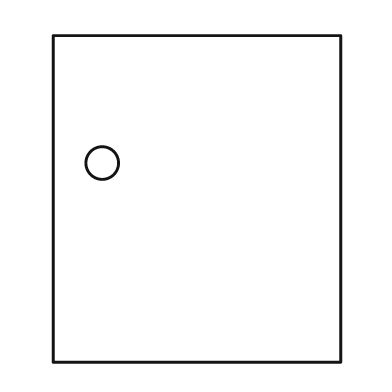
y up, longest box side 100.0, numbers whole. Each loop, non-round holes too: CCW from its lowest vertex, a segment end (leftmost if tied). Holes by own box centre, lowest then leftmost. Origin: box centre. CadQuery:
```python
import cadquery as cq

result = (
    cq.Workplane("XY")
    .moveTo(-44.0, -50.0)
    .lineTo(44.0, -50.0)
    .lineTo(44.0, 50.0)
    .lineTo(-44.0, 50.0)
    .close()
    .moveTo(-29.0, 11.0)
    .circle(5.0)
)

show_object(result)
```